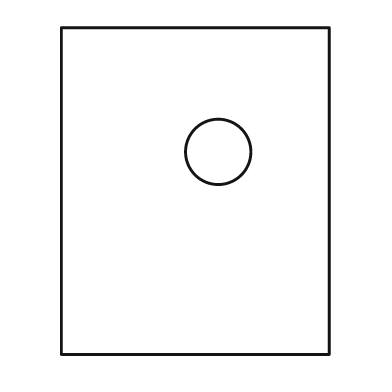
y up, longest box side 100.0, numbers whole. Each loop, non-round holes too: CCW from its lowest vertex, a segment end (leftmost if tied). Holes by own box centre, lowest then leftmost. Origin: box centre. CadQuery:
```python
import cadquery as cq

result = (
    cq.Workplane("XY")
    .moveTo(-41.0, -50.0)
    .lineTo(41.0, -50.0)
    .lineTo(41.0, 50.0)
    .lineTo(-41.0, 50.0)
    .close()
    .moveTo(7.0, 12.0)
    .circle(10.0)
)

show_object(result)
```